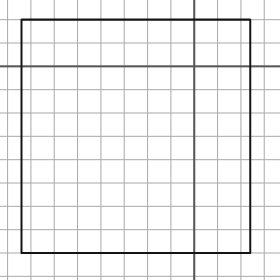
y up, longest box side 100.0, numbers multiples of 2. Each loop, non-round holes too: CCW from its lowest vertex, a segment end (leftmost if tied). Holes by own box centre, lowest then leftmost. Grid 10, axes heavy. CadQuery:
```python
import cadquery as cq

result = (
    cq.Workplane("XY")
    .moveTo(-74.0, -80.0)
    .lineTo(24.0, -80.0)
    .lineTo(24.0, 20.0)
    .lineTo(-74.0, 20.0)
    .close()
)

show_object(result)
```